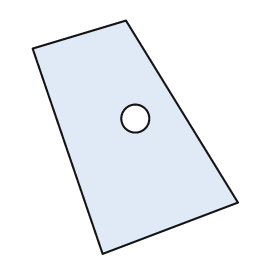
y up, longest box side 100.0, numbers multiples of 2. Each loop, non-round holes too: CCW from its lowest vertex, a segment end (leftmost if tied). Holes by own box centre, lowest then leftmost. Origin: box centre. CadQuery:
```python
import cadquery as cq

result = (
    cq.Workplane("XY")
    .moveTo(-14.0, -50.0)
    .lineTo(44.0, -28.0)
    .lineTo(-4.0, 50.0)
    .lineTo(-44.0, 38.0)
    .close()
    .moveTo(0.0, 8.0)
    .circle(6.0)
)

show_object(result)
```